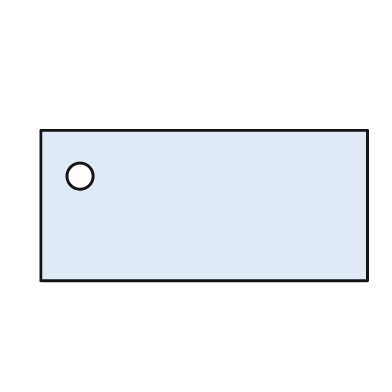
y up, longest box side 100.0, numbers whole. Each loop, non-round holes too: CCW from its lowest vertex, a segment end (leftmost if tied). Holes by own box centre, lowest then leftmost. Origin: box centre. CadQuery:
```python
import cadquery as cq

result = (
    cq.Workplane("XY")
    .moveTo(-50.0, -23.0)
    .lineTo(50.0, -23.0)
    .lineTo(50.0, 23.0)
    .lineTo(-50.0, 23.0)
    .close()
    .moveTo(-38.0, 9.0)
    .circle(4.0)
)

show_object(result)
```